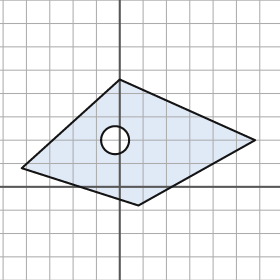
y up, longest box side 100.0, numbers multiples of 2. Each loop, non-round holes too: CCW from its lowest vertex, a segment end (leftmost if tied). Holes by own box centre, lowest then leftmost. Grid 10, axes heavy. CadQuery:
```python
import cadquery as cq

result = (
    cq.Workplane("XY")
    .moveTo(8.0, -8.0)
    .lineTo(58.0, 20.0)
    .lineTo(0.0, 46.0)
    .lineTo(-42.0, 8.0)
    .close()
    .moveTo(-2.0, 20.0)
    .circle(6.0)
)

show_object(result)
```